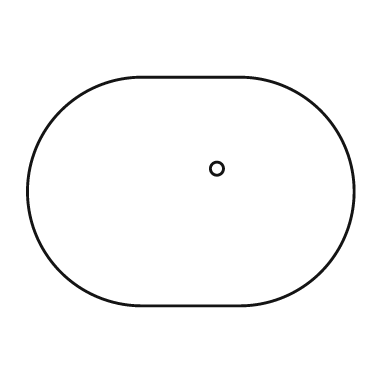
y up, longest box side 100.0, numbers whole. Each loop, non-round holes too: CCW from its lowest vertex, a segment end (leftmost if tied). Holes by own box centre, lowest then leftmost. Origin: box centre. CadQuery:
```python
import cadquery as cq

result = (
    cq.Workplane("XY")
    .moveTo(-15.0, -35.0)
    .lineTo(15.0, -35.0)
    .threePointArc((50.0, 0.0), (15.0, 35.0))
    .lineTo(-15.0, 35.0)
    .threePointArc((-50.0, 0.0), (-15.0, -35.0))
    .close()
    .moveTo(8.0, 7.0)
    .circle(2.0)
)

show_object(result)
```